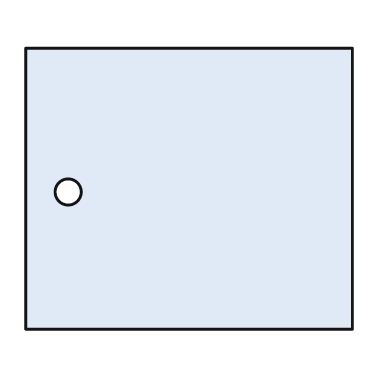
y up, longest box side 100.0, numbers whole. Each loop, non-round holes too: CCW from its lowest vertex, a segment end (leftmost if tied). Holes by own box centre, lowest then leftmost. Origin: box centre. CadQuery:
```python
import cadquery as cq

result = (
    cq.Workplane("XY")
    .moveTo(-50.0, -43.0)
    .lineTo(50.0, -43.0)
    .lineTo(50.0, 43.0)
    .lineTo(-50.0, 43.0)
    .close()
    .moveTo(-37.0, -1.0)
    .circle(4.0)
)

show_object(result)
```